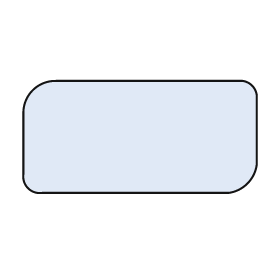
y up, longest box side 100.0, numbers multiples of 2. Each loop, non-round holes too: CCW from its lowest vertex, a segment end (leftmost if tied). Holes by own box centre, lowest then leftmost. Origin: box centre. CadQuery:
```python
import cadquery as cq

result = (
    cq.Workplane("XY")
    .moveTo(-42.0, -24.0)
    .lineTo(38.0, -24.0)
    .threePointArc((46.0, -20.0), (50.0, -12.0))
    .lineTo(50.0, 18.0)
    .threePointArc((48.0, 22.0), (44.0, 24.0))
    .lineTo(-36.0, 24.0)
    .threePointArc((-46.0, 20.0), (-50.0, 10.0))
    .lineTo(-50.0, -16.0)
    .threePointArc((-48.0, -22.0), (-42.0, -24.0))
    .close()
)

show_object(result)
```